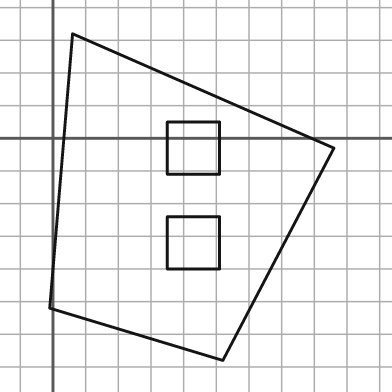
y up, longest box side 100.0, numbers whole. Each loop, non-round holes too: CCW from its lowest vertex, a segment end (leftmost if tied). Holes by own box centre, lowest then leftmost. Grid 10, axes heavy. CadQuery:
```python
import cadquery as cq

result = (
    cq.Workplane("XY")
    .moveTo(52.0, -68.0)
    .lineTo(86.0, -3.0)
    .lineTo(6.0, 32.0)
    .lineTo(-1.0, -52.0)
    .close()
    .moveTo(35.0, -40.0)
    .lineTo(51.0, -40.0)
    .lineTo(51.0, -24.0)
    .lineTo(35.0, -24.0)
    .close()
    .moveTo(35.0, -11.0)
    .lineTo(51.0, -11.0)
    .lineTo(51.0, 5.0)
    .lineTo(35.0, 5.0)
    .close()
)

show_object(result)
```